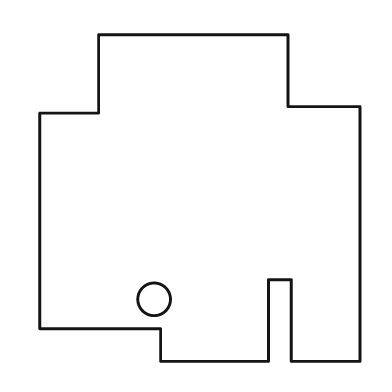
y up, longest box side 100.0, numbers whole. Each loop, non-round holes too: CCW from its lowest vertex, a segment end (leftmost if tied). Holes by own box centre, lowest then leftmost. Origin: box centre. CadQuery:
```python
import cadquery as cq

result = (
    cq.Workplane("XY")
    .moveTo(-12.0, -50.0)
    .lineTo(21.0, -50.0)
    .lineTo(21.0, -25.0)
    .lineTo(28.0, -25.0)
    .lineTo(28.0, -50.0)
    .lineTo(49.0, -50.0)
    .lineTo(49.0, 28.0)
    .lineTo(27.0, 28.0)
    .lineTo(27.0, 50.0)
    .lineTo(-31.0, 50.0)
    .lineTo(-31.0, 26.0)
    .lineTo(-49.0, 26.0)
    .lineTo(-49.0, -40.0)
    .lineTo(-12.0, -40.0)
    .close()
    .moveTo(-14.0, -31.0)
    .circle(5.0)
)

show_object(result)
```